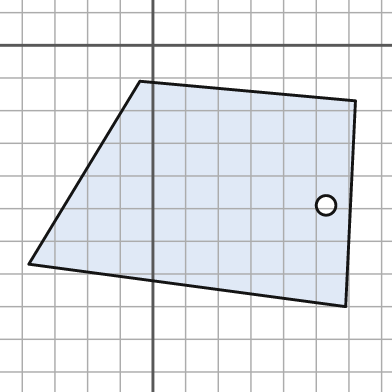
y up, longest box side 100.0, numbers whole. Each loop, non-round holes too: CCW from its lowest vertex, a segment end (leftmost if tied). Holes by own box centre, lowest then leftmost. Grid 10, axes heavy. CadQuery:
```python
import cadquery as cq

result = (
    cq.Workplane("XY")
    .moveTo(59.0, -80.0)
    .lineTo(62.0, -17.0)
    .lineTo(-4.0, -11.0)
    .lineTo(-38.0, -67.0)
    .close()
    .moveTo(53.0, -49.0)
    .circle(3.0)
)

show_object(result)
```